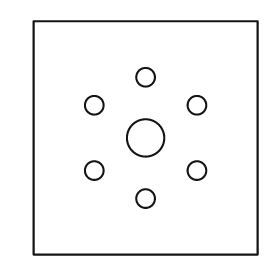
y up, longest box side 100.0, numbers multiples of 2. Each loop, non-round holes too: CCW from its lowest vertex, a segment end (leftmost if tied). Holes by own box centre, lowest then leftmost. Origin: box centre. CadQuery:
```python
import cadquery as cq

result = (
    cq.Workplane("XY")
    .moveTo(-48.0, -50.0)
    .lineTo(48.0, -50.0)
    .lineTo(48.0, 50.0)
    .lineTo(-48.0, 50.0)
    .close()
    .moveTo(0.0, -26.0)
    .circle(4.0)
    .moveTo(-22.0, -14.0)
    .circle(4.0)
    .moveTo(22.0, -14.0)
    .circle(4.0)
    .moveTo(0.0, 0.0)
    .circle(8.0)
    .moveTo(-22.0, 14.0)
    .circle(4.0)
    .moveTo(22.0, 14.0)
    .circle(4.0)
    .moveTo(0.0, 26.0)
    .circle(4.0)
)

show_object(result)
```